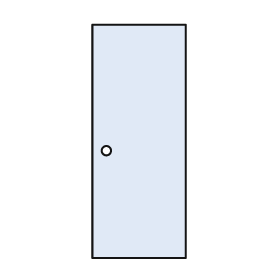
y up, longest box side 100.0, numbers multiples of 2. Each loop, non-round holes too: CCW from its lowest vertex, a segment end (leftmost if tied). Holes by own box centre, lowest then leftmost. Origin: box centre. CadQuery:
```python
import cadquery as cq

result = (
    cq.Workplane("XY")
    .moveTo(-20.0, -50.0)
    .lineTo(20.0, -50.0)
    .lineTo(20.0, 50.0)
    .lineTo(-20.0, 50.0)
    .close()
    .moveTo(-14.0, -4.0)
    .circle(2.0)
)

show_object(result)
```